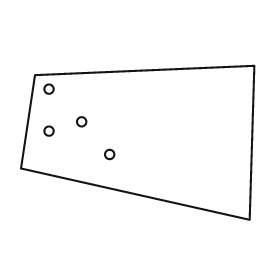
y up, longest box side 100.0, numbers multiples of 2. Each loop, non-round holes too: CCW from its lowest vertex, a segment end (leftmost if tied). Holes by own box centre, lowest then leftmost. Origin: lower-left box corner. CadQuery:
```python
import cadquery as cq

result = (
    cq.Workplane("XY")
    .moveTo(98.0, 0.0)
    .lineTo(100.0, 66.0)
    .lineTo(6.0, 62.0)
    .lineTo(0.0, 22.0)
    .close()
    .moveTo(38.0, 28.0)
    .circle(2.0)
    .moveTo(12.0, 38.0)
    .circle(2.0)
    .moveTo(26.0, 42.0)
    .circle(2.0)
    .moveTo(12.0, 56.0)
    .circle(2.0)
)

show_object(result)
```